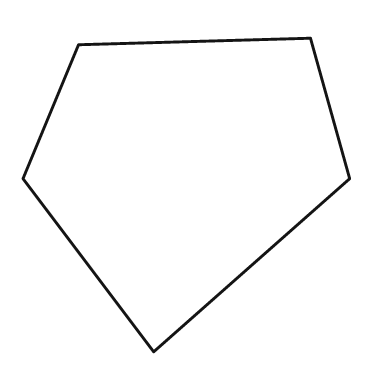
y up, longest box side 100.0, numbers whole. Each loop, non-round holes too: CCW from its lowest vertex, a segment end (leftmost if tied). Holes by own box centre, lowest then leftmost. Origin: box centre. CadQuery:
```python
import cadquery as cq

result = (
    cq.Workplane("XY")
    .moveTo(-10.0, -48.0)
    .lineTo(50.0, 5.0)
    .lineTo(38.0, 48.0)
    .lineTo(-33.0, 46.0)
    .lineTo(-50.0, 5.0)
    .close()
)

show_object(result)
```